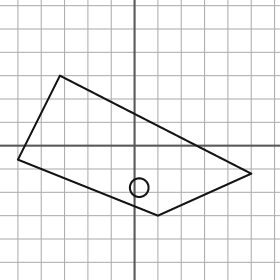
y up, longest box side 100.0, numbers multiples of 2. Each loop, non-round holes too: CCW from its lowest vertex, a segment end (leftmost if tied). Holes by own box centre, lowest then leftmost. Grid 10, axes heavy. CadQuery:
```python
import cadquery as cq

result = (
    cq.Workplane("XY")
    .moveTo(10.0, -30.0)
    .lineTo(50.0, -12.0)
    .lineTo(-32.0, 30.0)
    .lineTo(-50.0, -6.0)
    .close()
    .moveTo(2.0, -18.0)
    .circle(4.0)
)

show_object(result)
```